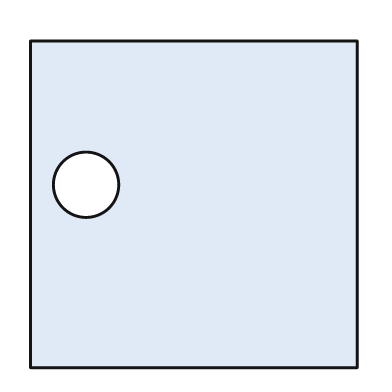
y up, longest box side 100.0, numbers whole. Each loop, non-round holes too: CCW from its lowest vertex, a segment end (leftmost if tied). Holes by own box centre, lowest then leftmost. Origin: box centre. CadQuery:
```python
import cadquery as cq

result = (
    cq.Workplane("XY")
    .moveTo(-50.0, -50.0)
    .lineTo(50.0, -50.0)
    .lineTo(50.0, 50.0)
    .lineTo(-50.0, 50.0)
    .close()
    .moveTo(-33.0, 6.0)
    .circle(10.0)
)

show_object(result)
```